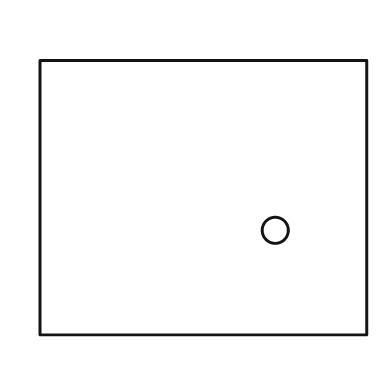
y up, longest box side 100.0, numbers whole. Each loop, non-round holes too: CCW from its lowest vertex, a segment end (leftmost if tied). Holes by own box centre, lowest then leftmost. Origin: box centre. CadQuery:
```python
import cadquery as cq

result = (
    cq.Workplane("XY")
    .moveTo(-50.0, -42.0)
    .lineTo(50.0, -42.0)
    .lineTo(50.0, 42.0)
    .lineTo(-50.0, 42.0)
    .close()
    .moveTo(22.0, -10.0)
    .circle(4.0)
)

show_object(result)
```